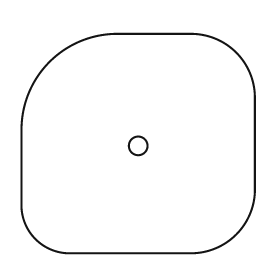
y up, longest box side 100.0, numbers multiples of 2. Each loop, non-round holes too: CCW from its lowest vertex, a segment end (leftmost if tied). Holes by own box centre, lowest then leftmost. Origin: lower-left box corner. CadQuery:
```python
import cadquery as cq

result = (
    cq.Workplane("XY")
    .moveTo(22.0, 0.0)
    .lineTo(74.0, 0.0)
    .threePointArc((92.0, 8.0), (100.0, 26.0))
    .lineTo(100.0, 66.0)
    .threePointArc((92.0, 86.0), (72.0, 94.0))
    .lineTo(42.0, 94.0)
    .threePointArc((12.0, 82.0), (0.0, 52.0))
    .lineTo(0.0, 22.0)
    .threePointArc((6.0, 6.0), (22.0, 0.0))
    .close()
    .moveTo(50.0, 46.0)
    .circle(4.0)
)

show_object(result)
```